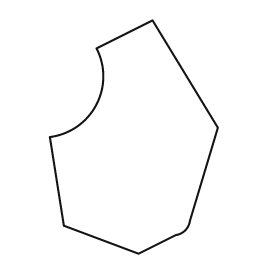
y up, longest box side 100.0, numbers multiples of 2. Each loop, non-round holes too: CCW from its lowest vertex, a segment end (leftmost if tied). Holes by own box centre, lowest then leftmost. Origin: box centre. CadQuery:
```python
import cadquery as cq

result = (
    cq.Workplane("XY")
    .moveTo(2.0, -50.0)
    .lineTo(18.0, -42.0)
    .threePointArc((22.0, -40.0), (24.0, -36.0))
    .lineTo(36.0, 4.0)
    .lineTo(8.0, 50.0)
    .lineTo(-16.0, 38.0)
    .threePointArc((-16.0, 14.0), (-36.0, 0.0))
    .lineTo(-30.0, -38.0)
    .close()
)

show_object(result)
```